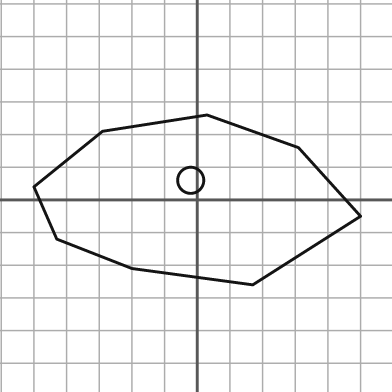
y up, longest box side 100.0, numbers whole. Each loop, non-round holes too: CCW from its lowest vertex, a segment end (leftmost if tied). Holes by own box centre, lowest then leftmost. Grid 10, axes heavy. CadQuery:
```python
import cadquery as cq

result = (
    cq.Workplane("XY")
    .moveTo(17.0, -26.0)
    .lineTo(50.0, -5.0)
    .lineTo(31.0, 16.0)
    .lineTo(3.0, 26.0)
    .lineTo(-29.0, 21.0)
    .lineTo(-50.0, 4.0)
    .lineTo(-43.0, -12.0)
    .lineTo(-20.0, -21.0)
    .close()
    .moveTo(-2.0, 6.0)
    .circle(4.0)
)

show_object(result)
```